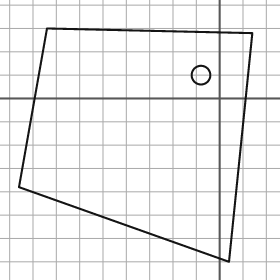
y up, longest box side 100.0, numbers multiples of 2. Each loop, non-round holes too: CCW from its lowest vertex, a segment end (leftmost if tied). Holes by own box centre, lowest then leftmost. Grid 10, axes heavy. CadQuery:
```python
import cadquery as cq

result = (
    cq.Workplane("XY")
    .moveTo(4.0, -70.0)
    .lineTo(14.0, 28.0)
    .lineTo(-74.0, 30.0)
    .lineTo(-86.0, -38.0)
    .close()
    .moveTo(-8.0, 10.0)
    .circle(4.0)
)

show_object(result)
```